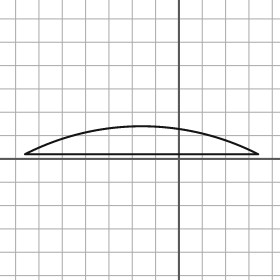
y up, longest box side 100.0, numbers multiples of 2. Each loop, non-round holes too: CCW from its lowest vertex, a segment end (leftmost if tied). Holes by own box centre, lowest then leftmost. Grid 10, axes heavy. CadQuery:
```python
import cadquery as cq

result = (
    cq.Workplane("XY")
    .moveTo(-66.0, 2.0)
    .lineTo(34.0, 2.0)
    .threePointArc((-16.0, 14.0), (-66.0, 2.0))
    .close()
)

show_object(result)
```